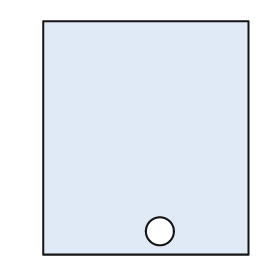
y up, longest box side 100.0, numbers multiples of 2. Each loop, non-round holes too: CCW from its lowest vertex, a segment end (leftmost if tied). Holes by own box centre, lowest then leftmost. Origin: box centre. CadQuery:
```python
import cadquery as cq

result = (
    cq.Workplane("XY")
    .moveTo(-44.0, -50.0)
    .lineTo(44.0, -50.0)
    .lineTo(44.0, 50.0)
    .lineTo(-44.0, 50.0)
    .close()
    .moveTo(6.0, -40.0)
    .circle(6.0)
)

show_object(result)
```